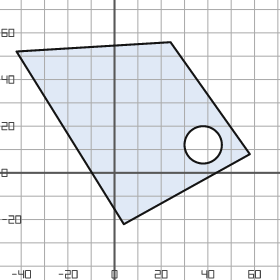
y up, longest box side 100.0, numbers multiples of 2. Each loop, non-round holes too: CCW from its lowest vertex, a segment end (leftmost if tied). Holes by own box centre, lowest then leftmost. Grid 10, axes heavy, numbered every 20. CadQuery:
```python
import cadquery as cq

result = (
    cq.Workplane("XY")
    .moveTo(4.0, -22.0)
    .lineTo(58.0, 8.0)
    .lineTo(24.0, 56.0)
    .lineTo(-42.0, 52.0)
    .close()
    .moveTo(38.0, 12.0)
    .circle(8.0)
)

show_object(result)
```